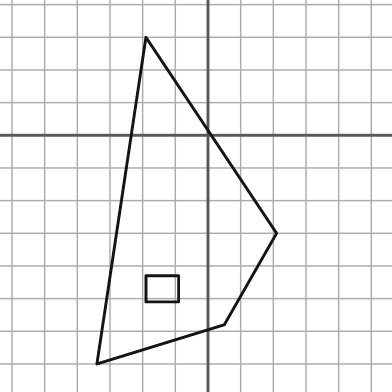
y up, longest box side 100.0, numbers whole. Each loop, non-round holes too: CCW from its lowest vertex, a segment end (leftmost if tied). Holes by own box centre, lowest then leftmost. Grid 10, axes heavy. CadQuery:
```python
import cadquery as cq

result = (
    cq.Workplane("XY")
    .moveTo(-34.0, -70.0)
    .lineTo(5.0, -58.0)
    .lineTo(21.0, -30.0)
    .lineTo(-19.0, 30.0)
    .close()
    .moveTo(-19.0, -51.0)
    .lineTo(-9.0, -51.0)
    .lineTo(-9.0, -43.0)
    .lineTo(-19.0, -43.0)
    .close()
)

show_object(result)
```